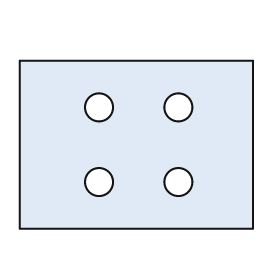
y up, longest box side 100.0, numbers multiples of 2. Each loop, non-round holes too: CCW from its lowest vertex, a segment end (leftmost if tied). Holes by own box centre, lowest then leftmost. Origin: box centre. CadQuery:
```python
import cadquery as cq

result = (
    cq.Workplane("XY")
    .moveTo(-50.0, -36.0)
    .lineTo(50.0, -36.0)
    .lineTo(50.0, 36.0)
    .lineTo(-50.0, 36.0)
    .close()
    .moveTo(-16.0, -16.0)
    .circle(6.0)
    .moveTo(18.0, -16.0)
    .circle(6.0)
    .moveTo(-16.0, 16.0)
    .circle(6.0)
    .moveTo(18.0, 16.0)
    .circle(6.0)
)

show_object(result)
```